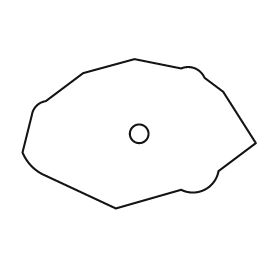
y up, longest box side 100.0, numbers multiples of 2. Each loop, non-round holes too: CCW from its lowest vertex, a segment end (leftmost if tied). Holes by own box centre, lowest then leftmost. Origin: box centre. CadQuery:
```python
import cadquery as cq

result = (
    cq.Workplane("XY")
    .moveTo(-10.0, -32.0)
    .lineTo(18.0, -24.0)
    .threePointArc((28.0, -24.0), (34.0, -16.0))
    .lineTo(50.0, -4.0)
    .lineTo(36.0, 18.0)
    .lineTo(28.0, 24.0)
    .threePointArc((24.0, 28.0), (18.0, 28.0))
    .lineTo(-2.0, 32.0)
    .lineTo(-24.0, 26.0)
    .lineTo(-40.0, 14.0)
    .threePointArc((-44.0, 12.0), (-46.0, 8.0))
    .lineTo(-50.0, -8.0)
    .threePointArc((-46.0, -14.0), (-40.0, -18.0))
    .close()
    .moveTo(0.0, 0.0)
    .circle(4.0)
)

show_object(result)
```